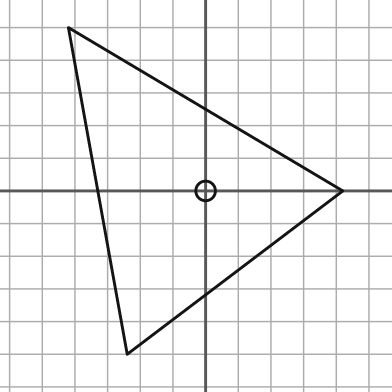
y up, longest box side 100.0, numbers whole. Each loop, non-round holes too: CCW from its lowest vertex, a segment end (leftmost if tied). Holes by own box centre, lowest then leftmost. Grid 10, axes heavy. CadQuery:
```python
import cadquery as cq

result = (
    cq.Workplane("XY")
    .moveTo(-24.0, -50.0)
    .lineTo(42.0, 0.0)
    .lineTo(-42.0, 50.0)
    .close()
    .moveTo(0.0, 0.0)
    .circle(3.0)
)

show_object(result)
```